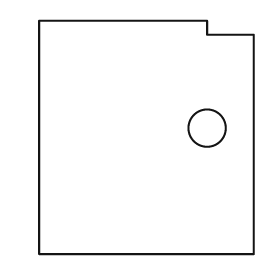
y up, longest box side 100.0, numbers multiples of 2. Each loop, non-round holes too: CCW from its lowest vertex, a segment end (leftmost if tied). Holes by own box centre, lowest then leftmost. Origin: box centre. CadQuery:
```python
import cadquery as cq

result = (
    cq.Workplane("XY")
    .moveTo(-46.0, -50.0)
    .lineTo(46.0, -50.0)
    .lineTo(46.0, 44.0)
    .lineTo(26.0, 44.0)
    .lineTo(26.0, 50.0)
    .lineTo(-46.0, 50.0)
    .close()
    .moveTo(26.0, 4.0)
    .circle(8.0)
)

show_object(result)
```